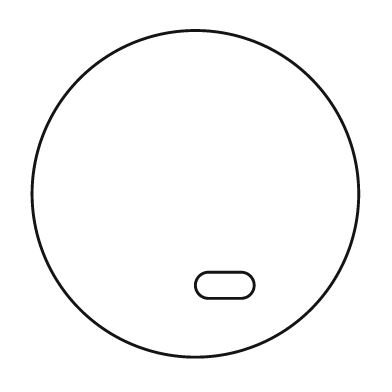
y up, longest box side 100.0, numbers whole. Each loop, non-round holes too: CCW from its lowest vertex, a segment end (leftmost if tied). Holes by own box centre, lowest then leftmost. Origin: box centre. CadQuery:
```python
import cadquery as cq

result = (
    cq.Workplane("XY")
    .moveTo(0.0, 0.0)
    .circle(50.0)
    .moveTo(4.0, -32.0)
    .lineTo(14.0, -32.0)
    .threePointArc((18.0, -28.0), (14.0, -24.0))
    .lineTo(4.0, -24.0)
    .threePointArc((0.0, -28.0), (4.0, -32.0))
    .close()
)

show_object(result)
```